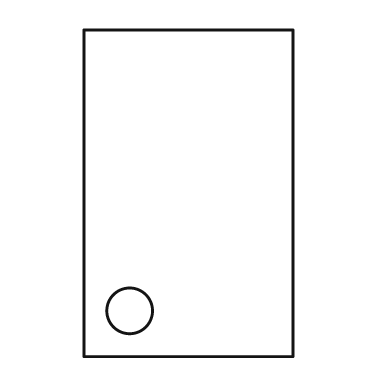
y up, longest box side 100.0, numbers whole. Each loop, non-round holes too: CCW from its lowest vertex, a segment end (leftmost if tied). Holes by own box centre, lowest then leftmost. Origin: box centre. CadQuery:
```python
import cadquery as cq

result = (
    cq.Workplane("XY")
    .moveTo(-32.0, -50.0)
    .lineTo(32.0, -50.0)
    .lineTo(32.0, 50.0)
    .lineTo(-32.0, 50.0)
    .close()
    .moveTo(-18.0, -36.0)
    .circle(7.0)
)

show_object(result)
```